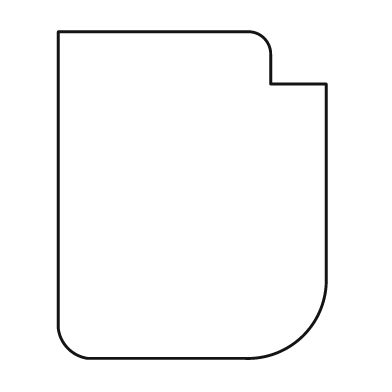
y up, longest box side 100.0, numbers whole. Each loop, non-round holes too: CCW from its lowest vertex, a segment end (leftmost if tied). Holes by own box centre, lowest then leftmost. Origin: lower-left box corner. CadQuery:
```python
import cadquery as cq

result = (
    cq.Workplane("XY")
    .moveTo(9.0, 0.0)
    .lineTo(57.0, 0.0)
    .threePointArc((75.0, 7.0), (82.0, 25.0))
    .lineTo(82.0, 84.0)
    .lineTo(65.0, 84.0)
    .lineTo(65.0, 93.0)
    .threePointArc((63.0, 98.0), (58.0, 100.0))
    .lineTo(0.0, 100.0)
    .lineTo(0.0, 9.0)
    .threePointArc((3.0, 3.0), (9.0, 0.0))
    .close()
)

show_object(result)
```